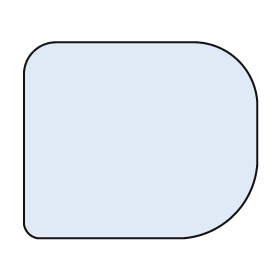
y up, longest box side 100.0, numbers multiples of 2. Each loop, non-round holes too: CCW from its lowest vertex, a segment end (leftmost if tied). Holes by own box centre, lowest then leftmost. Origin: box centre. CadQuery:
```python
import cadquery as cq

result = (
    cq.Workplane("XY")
    .moveTo(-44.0, -42.0)
    .lineTo(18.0, -42.0)
    .threePointArc((40.0, -32.0), (50.0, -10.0))
    .lineTo(50.0, 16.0)
    .threePointArc((42.0, 34.0), (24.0, 42.0))
    .lineTo(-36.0, 42.0)
    .threePointArc((-46.0, 38.0), (-50.0, 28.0))
    .lineTo(-50.0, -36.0)
    .threePointArc((-48.0, -40.0), (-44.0, -42.0))
    .close()
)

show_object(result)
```